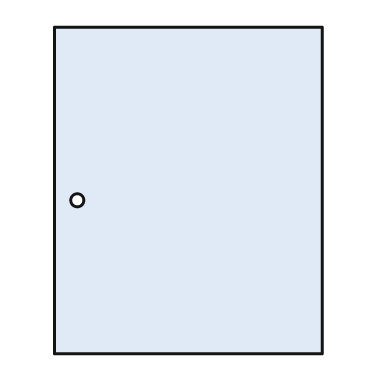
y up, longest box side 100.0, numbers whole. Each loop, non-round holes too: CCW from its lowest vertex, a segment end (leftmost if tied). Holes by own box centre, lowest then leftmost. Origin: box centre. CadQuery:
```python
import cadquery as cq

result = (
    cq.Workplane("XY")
    .moveTo(-41.0, -50.0)
    .lineTo(41.0, -50.0)
    .lineTo(41.0, 50.0)
    .lineTo(-41.0, 50.0)
    .close()
    .moveTo(-34.0, -3.0)
    .circle(2.0)
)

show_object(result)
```